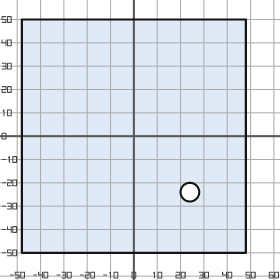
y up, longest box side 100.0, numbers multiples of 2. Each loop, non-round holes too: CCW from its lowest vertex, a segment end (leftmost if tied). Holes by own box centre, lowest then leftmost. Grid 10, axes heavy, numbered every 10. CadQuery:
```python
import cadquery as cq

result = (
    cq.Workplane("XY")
    .moveTo(-48.0, -50.0)
    .lineTo(48.0, -50.0)
    .lineTo(48.0, 50.0)
    .lineTo(-48.0, 50.0)
    .close()
    .moveTo(24.0, -24.0)
    .circle(4.0)
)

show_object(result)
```